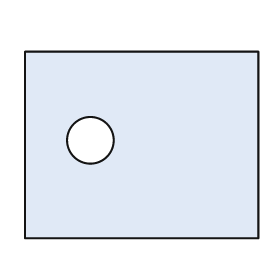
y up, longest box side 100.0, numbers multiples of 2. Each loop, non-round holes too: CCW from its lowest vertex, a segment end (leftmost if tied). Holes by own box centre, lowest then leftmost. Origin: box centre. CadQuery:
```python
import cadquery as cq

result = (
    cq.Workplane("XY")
    .moveTo(-50.0, -40.0)
    .lineTo(50.0, -40.0)
    .lineTo(50.0, 40.0)
    .lineTo(-50.0, 40.0)
    .close()
    .moveTo(-22.0, 2.0)
    .circle(10.0)
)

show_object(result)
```